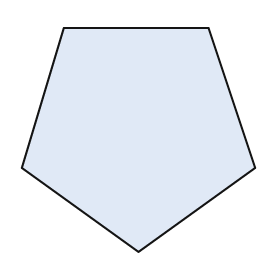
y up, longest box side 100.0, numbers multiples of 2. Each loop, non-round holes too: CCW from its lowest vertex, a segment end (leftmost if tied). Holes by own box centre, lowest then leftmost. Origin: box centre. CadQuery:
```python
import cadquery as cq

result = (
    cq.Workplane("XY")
    .moveTo(0.0, -48.0)
    .lineTo(50.0, -12.0)
    .lineTo(30.0, 48.0)
    .lineTo(-32.0, 48.0)
    .lineTo(-50.0, -12.0)
    .close()
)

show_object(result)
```